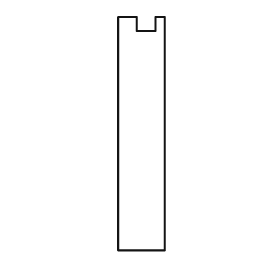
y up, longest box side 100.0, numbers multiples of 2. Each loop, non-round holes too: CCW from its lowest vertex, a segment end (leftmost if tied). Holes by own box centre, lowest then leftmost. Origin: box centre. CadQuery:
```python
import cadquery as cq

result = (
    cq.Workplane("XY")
    .moveTo(-10.0, -50.0)
    .lineTo(10.0, -50.0)
    .lineTo(10.0, 50.0)
    .lineTo(6.0, 50.0)
    .lineTo(6.0, 44.0)
    .lineTo(-2.0, 44.0)
    .lineTo(-2.0, 50.0)
    .lineTo(-10.0, 50.0)
    .close()
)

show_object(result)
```